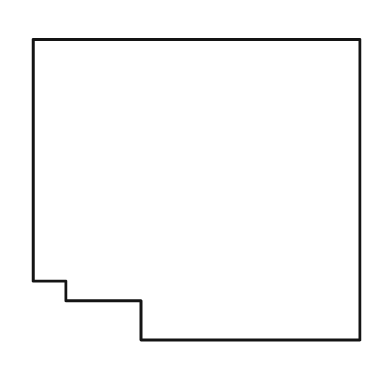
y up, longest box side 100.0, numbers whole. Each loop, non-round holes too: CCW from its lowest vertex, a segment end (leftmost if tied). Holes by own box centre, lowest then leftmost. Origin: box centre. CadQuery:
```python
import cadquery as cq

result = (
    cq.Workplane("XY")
    .moveTo(-17.0, -46.0)
    .lineTo(50.0, -46.0)
    .lineTo(50.0, 46.0)
    .lineTo(-50.0, 46.0)
    .lineTo(-50.0, -28.0)
    .lineTo(-40.0, -28.0)
    .lineTo(-40.0, -34.0)
    .lineTo(-17.0, -34.0)
    .close()
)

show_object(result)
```